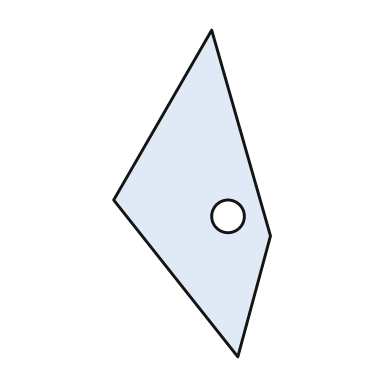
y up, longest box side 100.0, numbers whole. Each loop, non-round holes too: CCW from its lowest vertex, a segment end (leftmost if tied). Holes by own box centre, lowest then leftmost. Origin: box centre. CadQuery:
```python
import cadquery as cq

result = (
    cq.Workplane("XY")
    .moveTo(14.0, -50.0)
    .lineTo(24.0, -13.0)
    .lineTo(6.0, 50.0)
    .lineTo(-24.0, -2.0)
    .close()
    .moveTo(11.0, -7.0)
    .circle(5.0)
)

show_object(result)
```